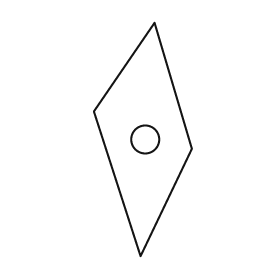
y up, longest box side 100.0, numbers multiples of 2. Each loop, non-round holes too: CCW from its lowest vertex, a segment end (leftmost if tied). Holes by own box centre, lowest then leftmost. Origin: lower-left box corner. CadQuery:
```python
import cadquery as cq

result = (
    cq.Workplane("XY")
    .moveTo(20.0, 0.0)
    .lineTo(42.0, 46.0)
    .lineTo(26.0, 100.0)
    .lineTo(0.0, 62.0)
    .close()
    .moveTo(22.0, 50.0)
    .circle(6.0)
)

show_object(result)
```